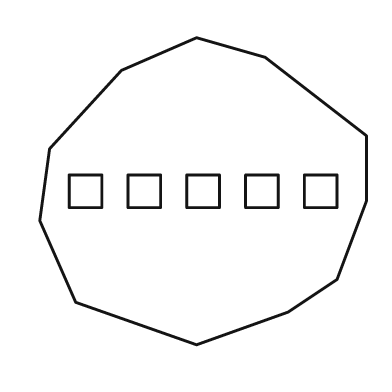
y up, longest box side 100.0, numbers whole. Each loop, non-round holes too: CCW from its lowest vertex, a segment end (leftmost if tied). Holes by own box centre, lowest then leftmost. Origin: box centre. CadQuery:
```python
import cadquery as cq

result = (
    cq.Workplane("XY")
    .moveTo(-2.0, -47.0)
    .lineTo(26.0, -37.0)
    .lineTo(41.0, -27.0)
    .lineTo(50.0, -3.0)
    .lineTo(50.0, 17.0)
    .lineTo(19.0, 41.0)
    .lineTo(-2.0, 47.0)
    .lineTo(-25.0, 37.0)
    .lineTo(-47.0, 13.0)
    .lineTo(-50.0, -9.0)
    .lineTo(-39.0, -34.0)
    .close()
    .moveTo(-41.0, -5.0)
    .lineTo(-31.0, -5.0)
    .lineTo(-31.0, 5.0)
    .lineTo(-41.0, 5.0)
    .close()
    .moveTo(-23.0, -5.0)
    .lineTo(-13.0, -5.0)
    .lineTo(-13.0, 5.0)
    .lineTo(-23.0, 5.0)
    .close()
    .moveTo(-5.0, -5.0)
    .lineTo(5.0, -5.0)
    .lineTo(5.0, 5.0)
    .lineTo(-5.0, 5.0)
    .close()
    .moveTo(13.0, -5.0)
    .lineTo(23.0, -5.0)
    .lineTo(23.0, 5.0)
    .lineTo(13.0, 5.0)
    .close()
    .moveTo(31.0, -5.0)
    .lineTo(41.0, -5.0)
    .lineTo(41.0, 5.0)
    .lineTo(31.0, 5.0)
    .close()
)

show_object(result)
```